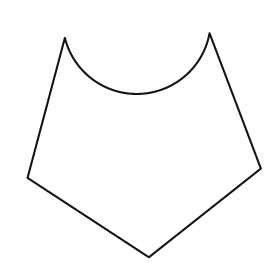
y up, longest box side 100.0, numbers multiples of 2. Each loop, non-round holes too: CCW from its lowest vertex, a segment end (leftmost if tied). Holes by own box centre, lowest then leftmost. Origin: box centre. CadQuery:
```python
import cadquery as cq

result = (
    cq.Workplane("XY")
    .moveTo(2.0, -48.0)
    .lineTo(50.0, -10.0)
    .lineTo(28.0, 48.0)
    .threePointArc((-2.0, 22.0), (-34.0, 46.0))
    .lineTo(-50.0, -14.0)
    .close()
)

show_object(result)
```